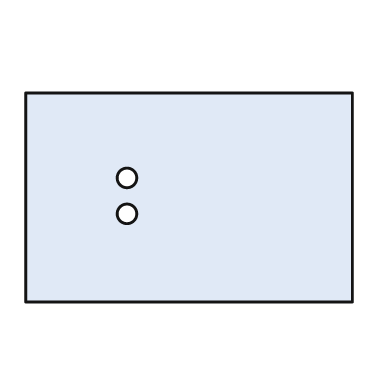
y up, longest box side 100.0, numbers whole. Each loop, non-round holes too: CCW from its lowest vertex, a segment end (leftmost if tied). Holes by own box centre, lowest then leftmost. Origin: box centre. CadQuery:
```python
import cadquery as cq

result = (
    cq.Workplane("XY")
    .moveTo(-50.0, -32.0)
    .lineTo(50.0, -32.0)
    .lineTo(50.0, 32.0)
    .lineTo(-50.0, 32.0)
    .close()
    .moveTo(-19.0, -5.0)
    .circle(3.0)
    .moveTo(-19.0, 6.0)
    .circle(3.0)
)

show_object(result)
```